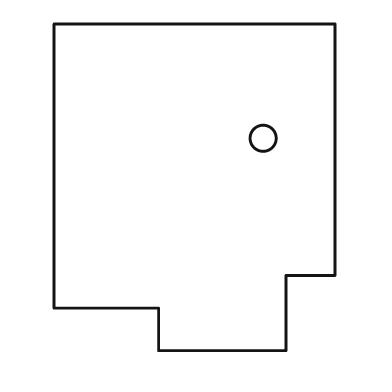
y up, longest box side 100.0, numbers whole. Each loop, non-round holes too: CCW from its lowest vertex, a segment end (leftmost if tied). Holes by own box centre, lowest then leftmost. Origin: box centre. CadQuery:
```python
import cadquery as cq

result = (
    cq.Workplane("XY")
    .moveTo(-11.0, -50.0)
    .lineTo(28.0, -50.0)
    .lineTo(28.0, -27.0)
    .lineTo(43.0, -27.0)
    .lineTo(43.0, 50.0)
    .lineTo(-43.0, 50.0)
    .lineTo(-43.0, -37.0)
    .lineTo(-11.0, -37.0)
    .close()
    .moveTo(21.0, 15.0)
    .circle(4.0)
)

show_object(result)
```